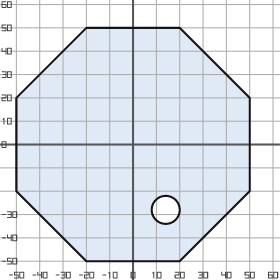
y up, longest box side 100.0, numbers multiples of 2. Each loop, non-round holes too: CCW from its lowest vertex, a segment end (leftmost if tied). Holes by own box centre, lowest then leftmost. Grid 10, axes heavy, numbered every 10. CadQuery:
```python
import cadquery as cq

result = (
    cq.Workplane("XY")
    .moveTo(-20.0, -50.0)
    .lineTo(20.0, -50.0)
    .lineTo(50.0, -20.0)
    .lineTo(50.0, 20.0)
    .lineTo(20.0, 50.0)
    .lineTo(-20.0, 50.0)
    .lineTo(-50.0, 20.0)
    .lineTo(-50.0, -20.0)
    .close()
    .moveTo(14.0, -28.0)
    .circle(6.0)
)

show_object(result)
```